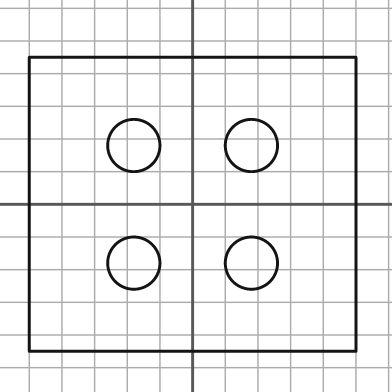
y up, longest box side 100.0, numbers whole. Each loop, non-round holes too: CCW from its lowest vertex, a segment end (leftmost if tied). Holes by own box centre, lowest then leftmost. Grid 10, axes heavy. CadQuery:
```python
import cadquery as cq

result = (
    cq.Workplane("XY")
    .moveTo(-50.0, -45.0)
    .lineTo(50.0, -45.0)
    .lineTo(50.0, 45.0)
    .lineTo(-50.0, 45.0)
    .close()
    .moveTo(-18.0, -18.0)
    .circle(8.0)
    .moveTo(18.0, -18.0)
    .circle(8.0)
    .moveTo(-18.0, 18.0)
    .circle(8.0)
    .moveTo(18.0, 18.0)
    .circle(8.0)
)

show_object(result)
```